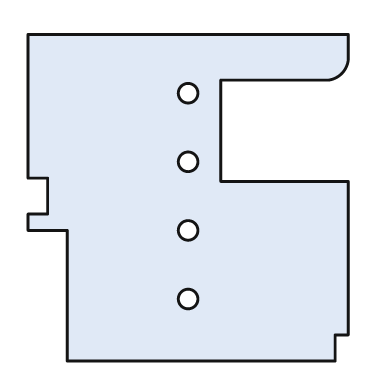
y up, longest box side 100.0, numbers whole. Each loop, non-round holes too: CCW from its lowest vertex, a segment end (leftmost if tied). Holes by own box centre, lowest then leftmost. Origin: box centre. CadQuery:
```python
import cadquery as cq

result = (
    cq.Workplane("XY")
    .moveTo(-37.0, -50.0)
    .lineTo(45.0, -50.0)
    .lineTo(45.0, -42.0)
    .lineTo(49.0, -42.0)
    .lineTo(49.0, 5.0)
    .lineTo(10.0, 5.0)
    .lineTo(10.0, 36.0)
    .lineTo(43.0, 36.0)
    .threePointArc((47.0, 38.0), (49.0, 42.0))
    .lineTo(49.0, 50.0)
    .lineTo(-49.0, 50.0)
    .lineTo(-49.0, 6.0)
    .lineTo(-43.0, 6.0)
    .lineTo(-43.0, -5.0)
    .lineTo(-49.0, -5.0)
    .lineTo(-49.0, -10.0)
    .lineTo(-37.0, -10.0)
    .close()
    .moveTo(0.0, -31.0)
    .circle(3.0)
    .moveTo(0.0, -10.0)
    .circle(3.0)
    .moveTo(0.0, 11.0)
    .circle(3.0)
    .moveTo(0.0, 32.0)
    .circle(3.0)
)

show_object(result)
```